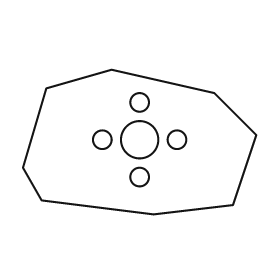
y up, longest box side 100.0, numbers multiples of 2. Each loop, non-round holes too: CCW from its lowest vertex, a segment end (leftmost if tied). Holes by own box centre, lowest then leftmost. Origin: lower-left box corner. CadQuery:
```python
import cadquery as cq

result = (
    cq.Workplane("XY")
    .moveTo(56.0, 0.0)
    .lineTo(90.0, 4.0)
    .lineTo(100.0, 34.0)
    .lineTo(82.0, 52.0)
    .lineTo(38.0, 62.0)
    .lineTo(10.0, 54.0)
    .lineTo(0.0, 20.0)
    .lineTo(8.0, 6.0)
    .close()
    .moveTo(50.0, 16.0)
    .circle(4.0)
    .moveTo(34.0, 32.0)
    .circle(4.0)
    .moveTo(50.0, 32.0)
    .circle(8.0)
    .moveTo(66.0, 32.0)
    .circle(4.0)
    .moveTo(50.0, 48.0)
    .circle(4.0)
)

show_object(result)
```